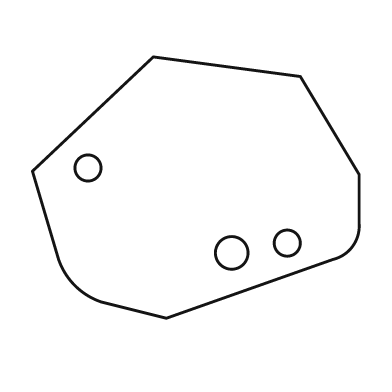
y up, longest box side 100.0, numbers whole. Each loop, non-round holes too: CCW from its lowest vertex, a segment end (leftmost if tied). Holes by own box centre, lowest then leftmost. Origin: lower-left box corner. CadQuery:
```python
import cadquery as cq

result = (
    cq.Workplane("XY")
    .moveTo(41.0, 0.0)
    .lineTo(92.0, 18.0)
    .threePointArc((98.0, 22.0), (100.0, 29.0))
    .lineTo(100.0, 44.0)
    .lineTo(82.0, 74.0)
    .lineTo(37.0, 80.0)
    .lineTo(0.0, 45.0)
    .lineTo(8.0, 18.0)
    .threePointArc((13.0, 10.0), (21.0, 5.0))
    .close()
    .moveTo(61.0, 20.0)
    .circle(5.0)
    .moveTo(78.0, 23.0)
    .circle(4.0)
    .moveTo(17.0, 46.0)
    .circle(4.0)
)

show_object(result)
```